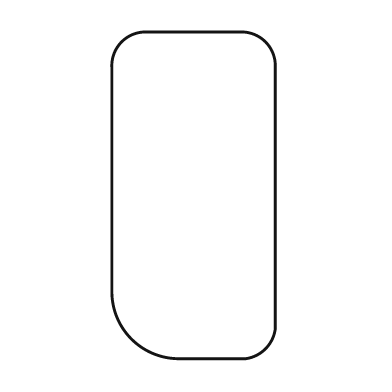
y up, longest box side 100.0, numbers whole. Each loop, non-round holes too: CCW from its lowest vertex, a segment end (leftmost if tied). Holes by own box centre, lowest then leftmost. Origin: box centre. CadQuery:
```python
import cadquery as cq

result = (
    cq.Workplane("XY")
    .moveTo(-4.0, -50.0)
    .lineTo(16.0, -50.0)
    .threePointArc((22.0, -47.0), (25.0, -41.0))
    .lineTo(25.0, 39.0)
    .threePointArc((22.0, 47.0), (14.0, 50.0))
    .lineTo(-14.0, 50.0)
    .threePointArc((-22.0, 47.0), (-25.0, 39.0))
    .lineTo(-25.0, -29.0)
    .threePointArc((-19.0, -44.0), (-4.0, -50.0))
    .close()
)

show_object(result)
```